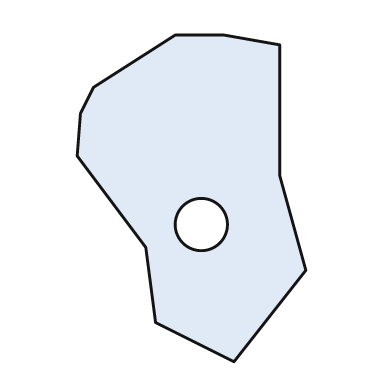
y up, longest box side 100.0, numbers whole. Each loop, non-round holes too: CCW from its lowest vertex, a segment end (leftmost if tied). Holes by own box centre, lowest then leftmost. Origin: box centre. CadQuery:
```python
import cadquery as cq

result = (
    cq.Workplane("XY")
    .moveTo(13.0, -50.0)
    .lineTo(35.0, -22.0)
    .lineTo(27.0, 7.0)
    .lineTo(27.0, 47.0)
    .lineTo(10.0, 50.0)
    .lineTo(-5.0, 50.0)
    .lineTo(-30.0, 34.0)
    .lineTo(-34.0, 26.0)
    .lineTo(-35.0, 13.0)
    .lineTo(-14.0, -15.0)
    .lineTo(-11.0, -38.0)
    .close()
    .moveTo(3.0, -8.0)
    .circle(8.0)
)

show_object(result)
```